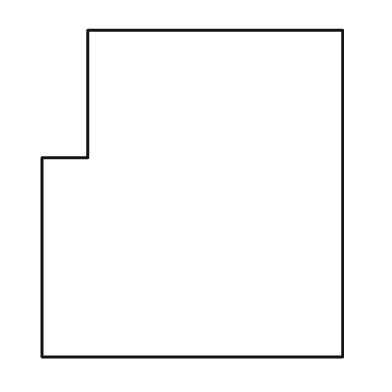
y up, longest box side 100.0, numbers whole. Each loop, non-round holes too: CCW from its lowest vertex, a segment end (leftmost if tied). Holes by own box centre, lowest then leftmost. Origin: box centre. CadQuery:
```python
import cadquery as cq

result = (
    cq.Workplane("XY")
    .moveTo(-46.0, -50.0)
    .lineTo(46.0, -50.0)
    .lineTo(46.0, 50.0)
    .lineTo(-32.0, 50.0)
    .lineTo(-32.0, 11.0)
    .lineTo(-46.0, 11.0)
    .close()
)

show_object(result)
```